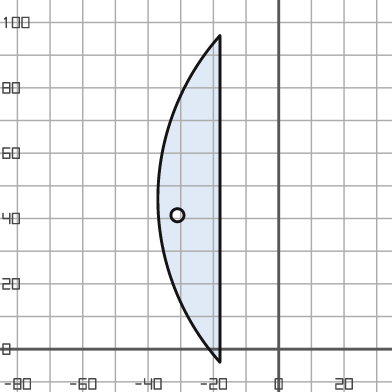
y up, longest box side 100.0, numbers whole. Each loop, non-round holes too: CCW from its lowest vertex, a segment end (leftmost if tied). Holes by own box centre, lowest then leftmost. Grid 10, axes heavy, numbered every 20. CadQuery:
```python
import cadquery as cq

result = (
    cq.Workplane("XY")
    .moveTo(-18.0, -4.0)
    .lineTo(-18.0, 96.0)
    .threePointArc((-37.0, 46.0), (-18.0, -4.0))
    .close()
    .moveTo(-31.0, 41.0)
    .circle(2.0)
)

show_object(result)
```